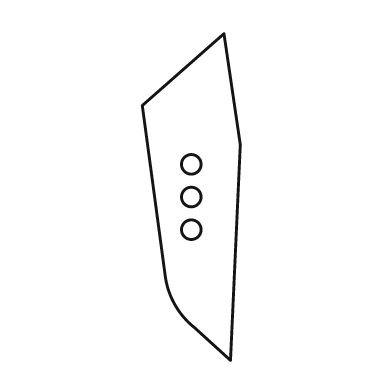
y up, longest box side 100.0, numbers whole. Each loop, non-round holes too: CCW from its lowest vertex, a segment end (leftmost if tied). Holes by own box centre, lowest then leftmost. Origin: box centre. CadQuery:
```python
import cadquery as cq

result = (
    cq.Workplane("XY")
    .moveTo(12.0, -50.0)
    .lineTo(15.0, 16.0)
    .lineTo(10.0, 50.0)
    .lineTo(-15.0, 28.0)
    .lineTo(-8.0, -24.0)
    .threePointArc((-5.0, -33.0), (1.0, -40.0))
    .close()
    .moveTo(0.0, -10.0)
    .circle(3.0)
    .moveTo(0.0, 0.0)
    .circle(3.0)
    .moveTo(0.0, 10.0)
    .circle(3.0)
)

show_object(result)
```